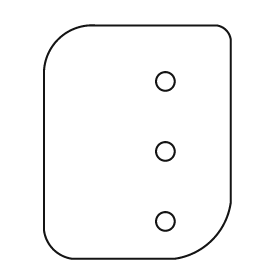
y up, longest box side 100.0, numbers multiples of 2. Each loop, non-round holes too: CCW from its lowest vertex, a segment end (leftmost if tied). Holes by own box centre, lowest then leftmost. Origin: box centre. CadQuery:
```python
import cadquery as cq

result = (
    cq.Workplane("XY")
    .moveTo(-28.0, -50.0)
    .lineTo(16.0, -50.0)
    .threePointArc((32.0, -42.0), (40.0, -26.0))
    .lineTo(40.0, 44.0)
    .threePointArc((38.0, 48.0), (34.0, 50.0))
    .lineTo(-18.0, 50.0)
    .threePointArc((-34.0, 44.0), (-40.0, 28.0))
    .lineTo(-40.0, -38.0)
    .threePointArc((-36.0, -46.0), (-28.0, -50.0))
    .close()
    .moveTo(12.0, -34.0)
    .circle(4.0)
    .moveTo(12.0, -4.0)
    .circle(4.0)
    .moveTo(12.0, 26.0)
    .circle(4.0)
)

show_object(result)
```